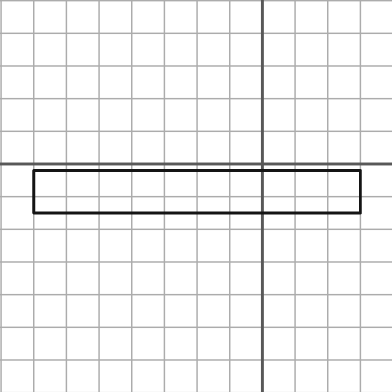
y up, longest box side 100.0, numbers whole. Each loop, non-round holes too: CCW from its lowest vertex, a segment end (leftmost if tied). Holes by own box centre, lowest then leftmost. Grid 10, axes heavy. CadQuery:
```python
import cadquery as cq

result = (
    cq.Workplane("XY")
    .moveTo(-70.0, -15.0)
    .lineTo(30.0, -15.0)
    .lineTo(30.0, -2.0)
    .lineTo(-70.0, -2.0)
    .close()
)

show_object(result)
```